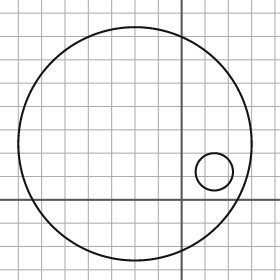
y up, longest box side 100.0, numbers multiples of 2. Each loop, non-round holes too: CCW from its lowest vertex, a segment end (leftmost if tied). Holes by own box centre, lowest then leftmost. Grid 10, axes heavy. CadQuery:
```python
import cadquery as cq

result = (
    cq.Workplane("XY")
    .moveTo(-20.0, 24.0)
    .circle(50.0)
    .moveTo(14.0, 12.0)
    .circle(8.0)
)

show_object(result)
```